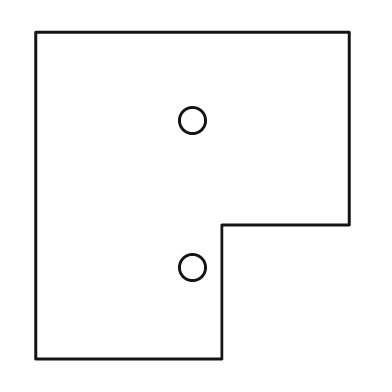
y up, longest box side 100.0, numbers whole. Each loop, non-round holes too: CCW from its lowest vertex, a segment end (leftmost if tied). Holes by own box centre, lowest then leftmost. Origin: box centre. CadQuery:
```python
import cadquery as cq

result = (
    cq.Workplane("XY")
    .moveTo(-48.0, -50.0)
    .lineTo(9.0, -50.0)
    .lineTo(9.0, -9.0)
    .lineTo(48.0, -9.0)
    .lineTo(48.0, 50.0)
    .lineTo(-48.0, 50.0)
    .close()
    .moveTo(0.0, -22.0)
    .circle(4.0)
    .moveTo(0.0, 23.0)
    .circle(4.0)
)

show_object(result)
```